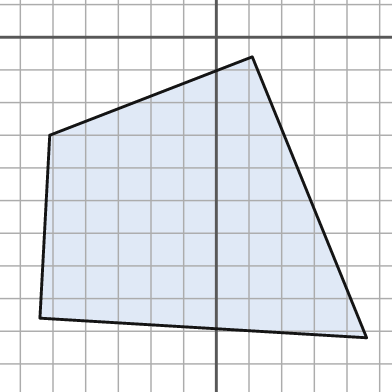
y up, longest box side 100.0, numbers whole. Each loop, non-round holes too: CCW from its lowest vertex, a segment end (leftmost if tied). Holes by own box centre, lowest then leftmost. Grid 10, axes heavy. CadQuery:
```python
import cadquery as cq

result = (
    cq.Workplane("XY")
    .moveTo(46.0, -92.0)
    .lineTo(11.0, -6.0)
    .lineTo(-51.0, -30.0)
    .lineTo(-54.0, -86.0)
    .close()
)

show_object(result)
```